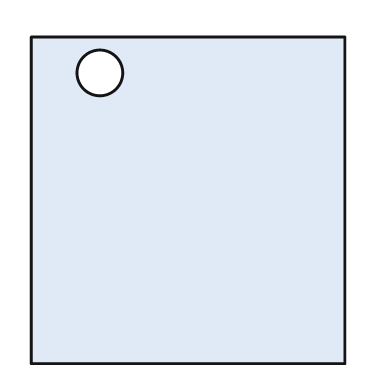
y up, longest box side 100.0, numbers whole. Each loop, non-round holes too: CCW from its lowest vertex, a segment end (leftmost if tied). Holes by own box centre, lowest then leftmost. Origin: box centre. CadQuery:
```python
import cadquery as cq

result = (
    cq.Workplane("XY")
    .moveTo(-48.0, -50.0)
    .lineTo(48.0, -50.0)
    .lineTo(48.0, 50.0)
    .lineTo(-48.0, 50.0)
    .close()
    .moveTo(-27.0, 39.0)
    .circle(7.0)
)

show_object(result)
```